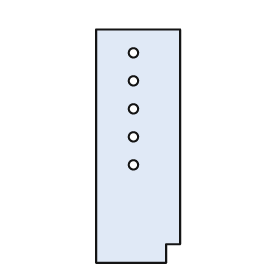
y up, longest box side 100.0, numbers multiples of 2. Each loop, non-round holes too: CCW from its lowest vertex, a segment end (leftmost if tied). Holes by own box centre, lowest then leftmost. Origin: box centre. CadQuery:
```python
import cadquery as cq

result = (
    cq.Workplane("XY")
    .moveTo(-18.0, -50.0)
    .lineTo(12.0, -50.0)
    .lineTo(12.0, -42.0)
    .lineTo(18.0, -42.0)
    .lineTo(18.0, 50.0)
    .lineTo(-18.0, 50.0)
    .close()
    .moveTo(-2.0, -8.0)
    .circle(2.0)
    .moveTo(-2.0, 4.0)
    .circle(2.0)
    .moveTo(-2.0, 16.0)
    .circle(2.0)
    .moveTo(-2.0, 28.0)
    .circle(2.0)
    .moveTo(-2.0, 40.0)
    .circle(2.0)
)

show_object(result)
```